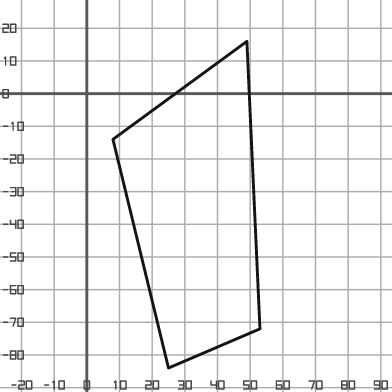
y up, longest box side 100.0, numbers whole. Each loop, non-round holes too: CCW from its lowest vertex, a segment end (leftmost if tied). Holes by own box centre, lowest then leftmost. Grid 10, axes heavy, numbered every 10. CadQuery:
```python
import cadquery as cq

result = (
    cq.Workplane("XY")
    .moveTo(25.0, -84.0)
    .lineTo(53.0, -72.0)
    .lineTo(49.0, 16.0)
    .lineTo(8.0, -14.0)
    .close()
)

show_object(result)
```